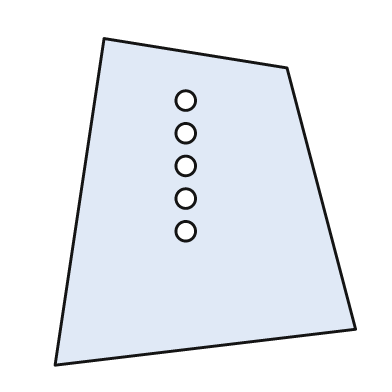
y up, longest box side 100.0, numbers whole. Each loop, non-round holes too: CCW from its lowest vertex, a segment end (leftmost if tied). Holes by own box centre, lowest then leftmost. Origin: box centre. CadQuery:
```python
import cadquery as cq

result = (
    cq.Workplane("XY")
    .moveTo(-46.0, -50.0)
    .lineTo(46.0, -39.0)
    .lineTo(25.0, 41.0)
    .lineTo(-31.0, 50.0)
    .close()
    .moveTo(-6.0, -9.0)
    .circle(3.0)
    .moveTo(-6.0, 1.0)
    .circle(3.0)
    .moveTo(-6.0, 11.0)
    .circle(3.0)
    .moveTo(-6.0, 21.0)
    .circle(3.0)
    .moveTo(-6.0, 31.0)
    .circle(3.0)
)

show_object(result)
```